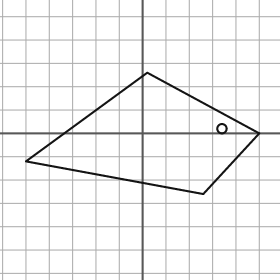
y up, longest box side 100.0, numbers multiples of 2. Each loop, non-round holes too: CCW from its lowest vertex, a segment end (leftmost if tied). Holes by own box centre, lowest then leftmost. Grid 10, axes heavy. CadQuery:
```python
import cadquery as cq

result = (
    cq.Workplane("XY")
    .moveTo(26.0, -26.0)
    .lineTo(50.0, 0.0)
    .lineTo(2.0, 26.0)
    .lineTo(-50.0, -12.0)
    .close()
    .moveTo(34.0, 2.0)
    .circle(2.0)
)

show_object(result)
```